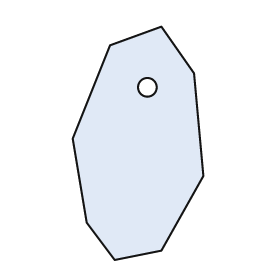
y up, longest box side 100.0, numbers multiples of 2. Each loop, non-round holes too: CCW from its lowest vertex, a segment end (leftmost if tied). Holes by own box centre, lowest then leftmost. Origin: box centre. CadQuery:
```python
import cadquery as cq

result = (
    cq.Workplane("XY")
    .moveTo(-10.0, -50.0)
    .lineTo(10.0, -46.0)
    .lineTo(28.0, -14.0)
    .lineTo(24.0, 30.0)
    .lineTo(10.0, 50.0)
    .lineTo(-12.0, 42.0)
    .lineTo(-28.0, 2.0)
    .lineTo(-22.0, -34.0)
    .close()
    .moveTo(4.0, 24.0)
    .circle(4.0)
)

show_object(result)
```